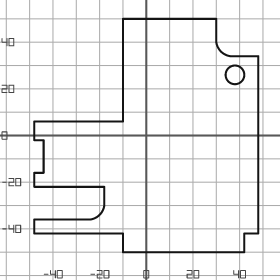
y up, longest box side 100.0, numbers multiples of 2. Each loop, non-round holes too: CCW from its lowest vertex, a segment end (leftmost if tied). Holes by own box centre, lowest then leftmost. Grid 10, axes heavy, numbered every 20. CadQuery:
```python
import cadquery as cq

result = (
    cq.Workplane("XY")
    .moveTo(-10.0, -50.0)
    .lineTo(42.0, -50.0)
    .lineTo(42.0, -42.0)
    .lineTo(48.0, -42.0)
    .lineTo(48.0, 34.0)
    .lineTo(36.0, 34.0)
    .threePointArc((32.0, 36.0), (30.0, 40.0))
    .lineTo(30.0, 50.0)
    .lineTo(-10.0, 50.0)
    .lineTo(-10.0, 6.0)
    .lineTo(-48.0, 6.0)
    .lineTo(-48.0, -2.0)
    .lineTo(-44.0, -2.0)
    .lineTo(-44.0, -16.0)
    .lineTo(-48.0, -16.0)
    .lineTo(-48.0, -22.0)
    .lineTo(-18.0, -22.0)
    .lineTo(-18.0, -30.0)
    .threePointArc((-20.0, -34.0), (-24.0, -36.0))
    .lineTo(-48.0, -36.0)
    .lineTo(-48.0, -42.0)
    .lineTo(-10.0, -42.0)
    .close()
    .moveTo(38.0, 26.0)
    .circle(4.0)
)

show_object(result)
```